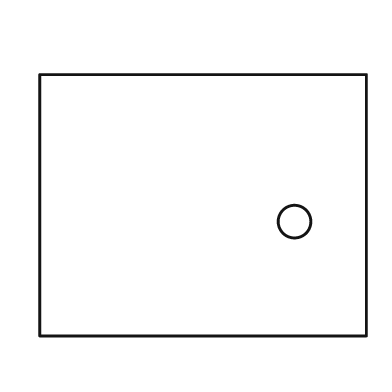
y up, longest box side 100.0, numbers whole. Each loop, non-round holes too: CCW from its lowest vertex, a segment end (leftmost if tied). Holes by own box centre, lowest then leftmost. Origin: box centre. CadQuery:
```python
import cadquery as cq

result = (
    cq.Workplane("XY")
    .moveTo(-50.0, -40.0)
    .lineTo(50.0, -40.0)
    .lineTo(50.0, 40.0)
    .lineTo(-50.0, 40.0)
    .close()
    .moveTo(28.0, -5.0)
    .circle(5.0)
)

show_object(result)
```